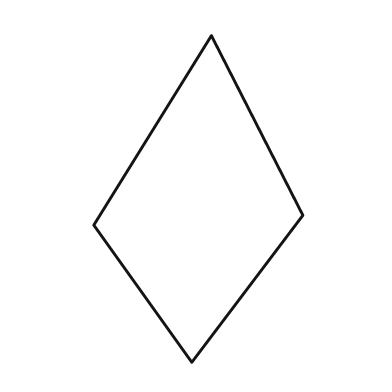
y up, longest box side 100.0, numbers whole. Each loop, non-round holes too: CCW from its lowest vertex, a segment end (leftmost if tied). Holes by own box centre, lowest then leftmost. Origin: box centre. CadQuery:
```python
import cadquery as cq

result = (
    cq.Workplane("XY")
    .moveTo(-2.0, -50.0)
    .lineTo(32.0, -5.0)
    .lineTo(4.0, 50.0)
    .lineTo(-32.0, -8.0)
    .close()
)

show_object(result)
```